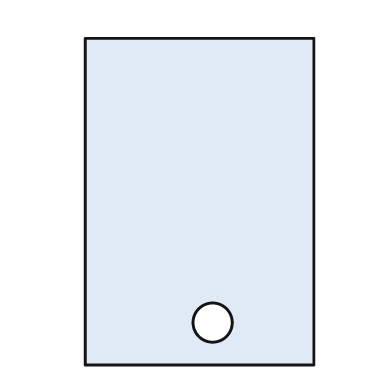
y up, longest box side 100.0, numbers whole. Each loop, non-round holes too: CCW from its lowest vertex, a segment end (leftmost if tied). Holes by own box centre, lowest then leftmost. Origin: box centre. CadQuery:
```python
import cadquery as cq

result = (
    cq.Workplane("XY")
    .moveTo(-35.0, -50.0)
    .lineTo(35.0, -50.0)
    .lineTo(35.0, 50.0)
    .lineTo(-35.0, 50.0)
    .close()
    .moveTo(4.0, -37.0)
    .circle(6.0)
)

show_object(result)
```